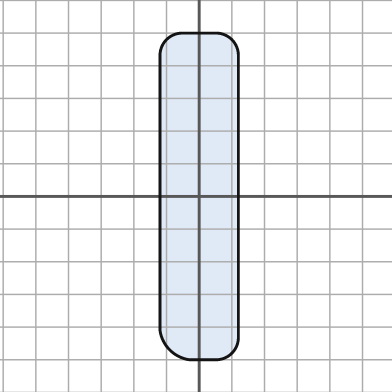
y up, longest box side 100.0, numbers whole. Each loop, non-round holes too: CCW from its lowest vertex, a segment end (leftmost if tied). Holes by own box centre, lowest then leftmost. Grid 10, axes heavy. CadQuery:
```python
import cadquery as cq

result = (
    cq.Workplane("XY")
    .moveTo(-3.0, -50.0)
    .lineTo(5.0, -50.0)
    .threePointArc((10.0, -48.0), (12.0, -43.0))
    .lineTo(12.0, 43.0)
    .threePointArc((10.0, 48.0), (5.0, 50.0))
    .lineTo(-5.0, 50.0)
    .threePointArc((-10.0, 48.0), (-12.0, 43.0))
    .lineTo(-12.0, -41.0)
    .threePointArc((-9.0, -47.0), (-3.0, -50.0))
    .close()
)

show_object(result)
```